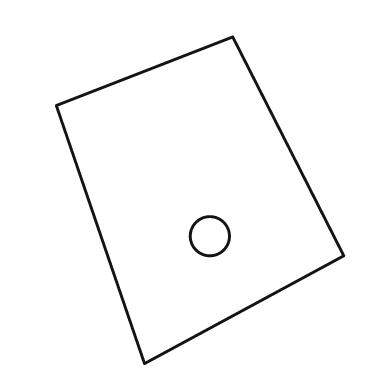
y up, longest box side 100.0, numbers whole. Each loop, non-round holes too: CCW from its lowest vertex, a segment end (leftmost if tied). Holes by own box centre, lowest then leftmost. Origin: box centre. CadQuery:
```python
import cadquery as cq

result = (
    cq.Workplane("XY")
    .moveTo(-17.0, -50.0)
    .lineTo(44.0, -17.0)
    .lineTo(10.0, 50.0)
    .lineTo(-44.0, 29.0)
    .close()
    .moveTo(3.0, -11.0)
    .circle(6.0)
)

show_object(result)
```